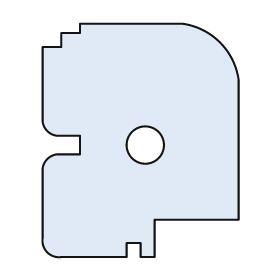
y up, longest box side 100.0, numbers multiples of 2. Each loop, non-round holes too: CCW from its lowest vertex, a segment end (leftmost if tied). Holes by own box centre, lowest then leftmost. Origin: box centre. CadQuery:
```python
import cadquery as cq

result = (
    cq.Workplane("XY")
    .moveTo(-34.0, -50.0)
    .lineTo(-6.0, -50.0)
    .lineTo(-6.0, -44.0)
    .lineTo(0.0, -44.0)
    .lineTo(0.0, -50.0)
    .lineTo(6.0, -50.0)
    .lineTo(6.0, -34.0)
    .lineTo(42.0, -34.0)
    .lineTo(42.0, 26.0)
    .threePointArc((34.0, 42.0), (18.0, 50.0))
    .lineTo(-26.0, 50.0)
    .lineTo(-26.0, 46.0)
    .lineTo(-34.0, 46.0)
    .lineTo(-34.0, 40.0)
    .lineTo(-42.0, 40.0)
    .lineTo(-42.0, 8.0)
    .threePointArc((-40.0, 4.0), (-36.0, 2.0))
    .lineTo(-26.0, 2.0)
    .lineTo(-26.0, -6.0)
    .lineTo(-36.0, -6.0)
    .threePointArc((-40.0, -8.0), (-42.0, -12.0))
    .lineTo(-42.0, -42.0)
    .threePointArc((-40.0, -48.0), (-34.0, -50.0))
    .close()
    .moveTo(2.0, -2.0)
    .circle(8.0)
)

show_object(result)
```